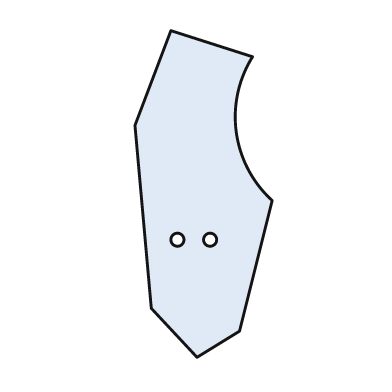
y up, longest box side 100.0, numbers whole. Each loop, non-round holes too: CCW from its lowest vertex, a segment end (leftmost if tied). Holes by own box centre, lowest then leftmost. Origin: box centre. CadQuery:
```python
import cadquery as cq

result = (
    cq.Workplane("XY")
    .moveTo(-2.0, -50.0)
    .lineTo(11.0, -42.0)
    .lineTo(21.0, -2.0)
    .threePointArc((10.0, 19.0), (15.0, 42.0))
    .lineTo(-10.0, 50.0)
    .lineTo(-21.0, 21.0)
    .lineTo(-16.0, -35.0)
    .close()
    .moveTo(-8.0, -14.0)
    .circle(2.0)
    .moveTo(2.0, -14.0)
    .circle(2.0)
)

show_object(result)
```